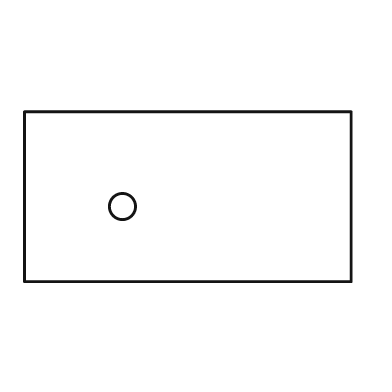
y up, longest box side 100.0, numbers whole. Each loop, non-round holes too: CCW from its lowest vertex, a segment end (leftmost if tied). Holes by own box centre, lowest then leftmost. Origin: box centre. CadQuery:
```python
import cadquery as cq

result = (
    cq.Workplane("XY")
    .moveTo(-50.0, -26.0)
    .lineTo(50.0, -26.0)
    .lineTo(50.0, 26.0)
    .lineTo(-50.0, 26.0)
    .close()
    .moveTo(-20.0, -3.0)
    .circle(4.0)
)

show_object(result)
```